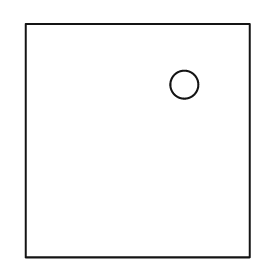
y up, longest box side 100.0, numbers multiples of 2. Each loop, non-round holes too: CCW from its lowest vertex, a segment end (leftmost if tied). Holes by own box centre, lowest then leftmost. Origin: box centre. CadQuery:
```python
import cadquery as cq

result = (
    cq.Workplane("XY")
    .moveTo(-48.0, -50.0)
    .lineTo(48.0, -50.0)
    .lineTo(48.0, 50.0)
    .lineTo(-48.0, 50.0)
    .close()
    .moveTo(20.0, 24.0)
    .circle(6.0)
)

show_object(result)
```